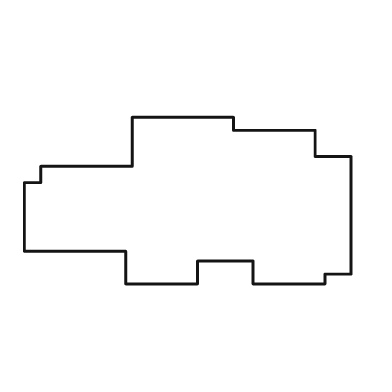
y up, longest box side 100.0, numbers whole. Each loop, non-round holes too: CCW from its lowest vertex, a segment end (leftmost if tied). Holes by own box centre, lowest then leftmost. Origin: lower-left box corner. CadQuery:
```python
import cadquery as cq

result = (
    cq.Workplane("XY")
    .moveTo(31.0, 0.0)
    .lineTo(53.0, 0.0)
    .lineTo(53.0, 7.0)
    .lineTo(70.0, 7.0)
    .lineTo(70.0, 0.0)
    .lineTo(92.0, 0.0)
    .lineTo(92.0, 3.0)
    .lineTo(100.0, 3.0)
    .lineTo(100.0, 39.0)
    .lineTo(89.0, 39.0)
    .lineTo(89.0, 47.0)
    .lineTo(64.0, 47.0)
    .lineTo(64.0, 51.0)
    .lineTo(33.0, 51.0)
    .lineTo(33.0, 36.0)
    .lineTo(5.0, 36.0)
    .lineTo(5.0, 31.0)
    .lineTo(0.0, 31.0)
    .lineTo(0.0, 10.0)
    .lineTo(31.0, 10.0)
    .close()
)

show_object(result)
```